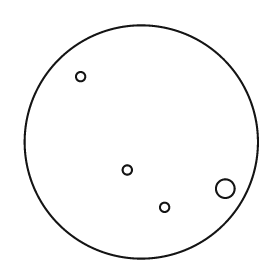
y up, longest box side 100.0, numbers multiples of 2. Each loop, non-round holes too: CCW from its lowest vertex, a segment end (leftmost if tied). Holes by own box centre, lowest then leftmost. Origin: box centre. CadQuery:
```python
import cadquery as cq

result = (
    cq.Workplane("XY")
    .moveTo(0.0, 0.0)
    .circle(50.0)
    .moveTo(10.0, -28.0)
    .circle(2.0)
    .moveTo(36.0, -20.0)
    .circle(4.0)
    .moveTo(-6.0, -12.0)
    .circle(2.0)
    .moveTo(-26.0, 28.0)
    .circle(2.0)
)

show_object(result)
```